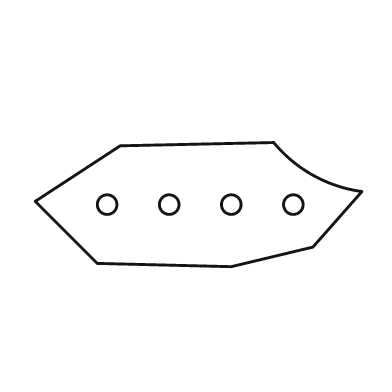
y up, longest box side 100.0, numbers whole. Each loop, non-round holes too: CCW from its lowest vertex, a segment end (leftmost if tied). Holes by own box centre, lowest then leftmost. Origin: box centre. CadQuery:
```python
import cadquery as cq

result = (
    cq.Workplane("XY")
    .moveTo(10.0, -19.0)
    .lineTo(35.0, -13.0)
    .lineTo(50.0, 4.0)
    .threePointArc((35.0, 9.0), (23.0, 19.0))
    .lineTo(-24.0, 18.0)
    .lineTo(-50.0, 1.0)
    .lineTo(-31.0, -18.0)
    .close()
    .moveTo(-28.0, 0.0)
    .circle(3.0)
    .moveTo(-9.0, 0.0)
    .circle(3.0)
    .moveTo(10.0, 0.0)
    .circle(3.0)
    .moveTo(29.0, 0.0)
    .circle(3.0)
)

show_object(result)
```